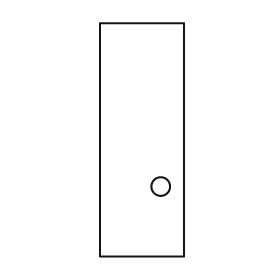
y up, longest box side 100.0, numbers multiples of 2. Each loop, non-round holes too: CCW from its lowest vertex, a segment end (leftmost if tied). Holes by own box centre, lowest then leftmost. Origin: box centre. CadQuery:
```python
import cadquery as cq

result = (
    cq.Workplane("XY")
    .moveTo(-18.0, -50.0)
    .lineTo(18.0, -50.0)
    .lineTo(18.0, 50.0)
    .lineTo(-18.0, 50.0)
    .close()
    .moveTo(8.0, -20.0)
    .circle(4.0)
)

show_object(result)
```